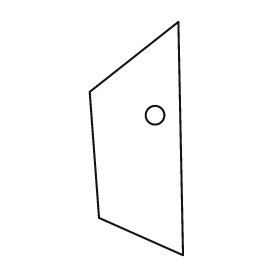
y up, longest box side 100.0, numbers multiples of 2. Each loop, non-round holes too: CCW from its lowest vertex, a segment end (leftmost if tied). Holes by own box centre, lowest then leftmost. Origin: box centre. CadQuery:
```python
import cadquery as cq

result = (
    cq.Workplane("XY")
    .moveTo(20.0, -50.0)
    .lineTo(18.0, 50.0)
    .lineTo(-20.0, 20.0)
    .lineTo(-16.0, -34.0)
    .close()
    .moveTo(8.0, 10.0)
    .circle(4.0)
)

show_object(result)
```